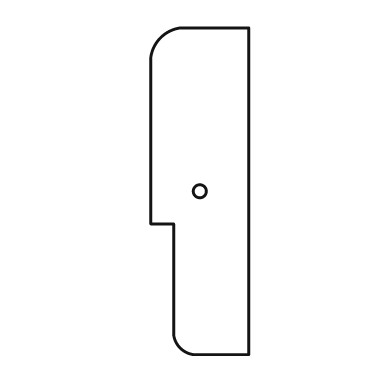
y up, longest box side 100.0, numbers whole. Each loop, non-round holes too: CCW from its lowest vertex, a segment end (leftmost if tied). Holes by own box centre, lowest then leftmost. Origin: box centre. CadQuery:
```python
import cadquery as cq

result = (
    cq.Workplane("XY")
    .moveTo(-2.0, -50.0)
    .lineTo(15.0, -50.0)
    .lineTo(15.0, 50.0)
    .lineTo(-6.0, 50.0)
    .threePointArc((-12.0, 47.0), (-15.0, 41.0))
    .lineTo(-15.0, -10.0)
    .lineTo(-8.0, -10.0)
    .lineTo(-8.0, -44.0)
    .threePointArc((-6.0, -48.0), (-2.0, -50.0))
    .close()
    .moveTo(0.0, 0.0)
    .circle(2.0)
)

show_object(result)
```